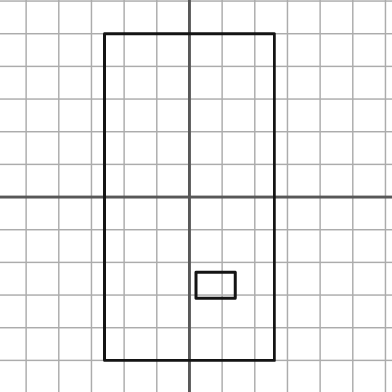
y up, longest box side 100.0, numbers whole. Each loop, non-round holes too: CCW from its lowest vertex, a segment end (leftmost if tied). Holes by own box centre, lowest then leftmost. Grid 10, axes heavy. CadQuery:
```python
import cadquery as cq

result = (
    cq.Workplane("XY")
    .moveTo(-26.0, -50.0)
    .lineTo(26.0, -50.0)
    .lineTo(26.0, 50.0)
    .lineTo(-26.0, 50.0)
    .close()
    .moveTo(2.0, -31.0)
    .lineTo(14.0, -31.0)
    .lineTo(14.0, -23.0)
    .lineTo(2.0, -23.0)
    .close()
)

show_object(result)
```